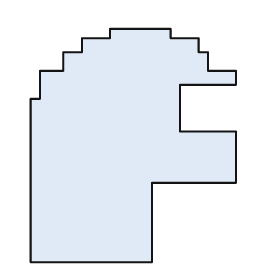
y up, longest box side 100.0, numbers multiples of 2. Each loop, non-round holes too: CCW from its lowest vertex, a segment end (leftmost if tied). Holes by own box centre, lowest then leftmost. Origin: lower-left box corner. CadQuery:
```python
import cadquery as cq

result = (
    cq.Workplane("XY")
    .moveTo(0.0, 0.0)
    .lineTo(52.0, 0.0)
    .lineTo(52.0, 34.0)
    .lineTo(88.0, 34.0)
    .lineTo(88.0, 56.0)
    .lineTo(64.0, 56.0)
    .lineTo(64.0, 76.0)
    .lineTo(88.0, 76.0)
    .lineTo(88.0, 82.0)
    .lineTo(76.0, 82.0)
    .lineTo(76.0, 90.0)
    .lineTo(72.0, 90.0)
    .lineTo(72.0, 96.0)
    .lineTo(60.0, 96.0)
    .lineTo(60.0, 100.0)
    .lineTo(34.0, 100.0)
    .lineTo(34.0, 96.0)
    .lineTo(22.0, 96.0)
    .lineTo(22.0, 90.0)
    .lineTo(14.0, 90.0)
    .lineTo(14.0, 82.0)
    .lineTo(4.0, 82.0)
    .lineTo(4.0, 70.0)
    .lineTo(0.0, 70.0)
    .close()
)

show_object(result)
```